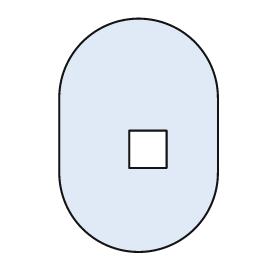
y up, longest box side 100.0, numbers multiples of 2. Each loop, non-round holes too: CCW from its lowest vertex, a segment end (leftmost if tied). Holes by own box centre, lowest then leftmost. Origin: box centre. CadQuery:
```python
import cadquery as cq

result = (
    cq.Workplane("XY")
    .moveTo(-34.0, -16.0)
    .threePointArc((0.0, -50.0), (34.0, -16.0))
    .lineTo(34.0, 16.0)
    .threePointArc((0.0, 50.0), (-34.0, 16.0))
    .close()
    .moveTo(-4.0, -14.0)
    .lineTo(12.0, -14.0)
    .lineTo(12.0, 2.0)
    .lineTo(-4.0, 2.0)
    .close()
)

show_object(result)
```